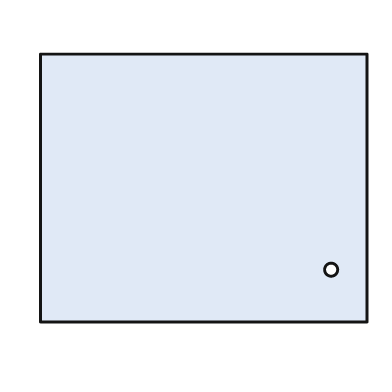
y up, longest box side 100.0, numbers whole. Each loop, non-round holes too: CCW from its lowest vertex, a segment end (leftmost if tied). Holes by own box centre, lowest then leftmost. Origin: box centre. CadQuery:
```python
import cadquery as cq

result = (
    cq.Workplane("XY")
    .moveTo(-50.0, -41.0)
    .lineTo(50.0, -41.0)
    .lineTo(50.0, 41.0)
    .lineTo(-50.0, 41.0)
    .close()
    .moveTo(39.0, -25.0)
    .circle(2.0)
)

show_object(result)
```